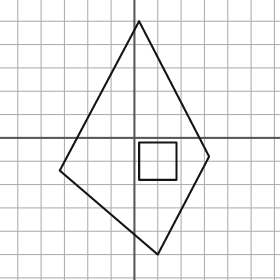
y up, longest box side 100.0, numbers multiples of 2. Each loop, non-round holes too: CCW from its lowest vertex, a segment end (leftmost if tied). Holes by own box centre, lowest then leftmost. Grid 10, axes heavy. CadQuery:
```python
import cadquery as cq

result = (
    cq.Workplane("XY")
    .moveTo(10.0, -50.0)
    .lineTo(32.0, -8.0)
    .lineTo(2.0, 50.0)
    .lineTo(-32.0, -14.0)
    .close()
    .moveTo(2.0, -18.0)
    .lineTo(18.0, -18.0)
    .lineTo(18.0, -2.0)
    .lineTo(2.0, -2.0)
    .close()
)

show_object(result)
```